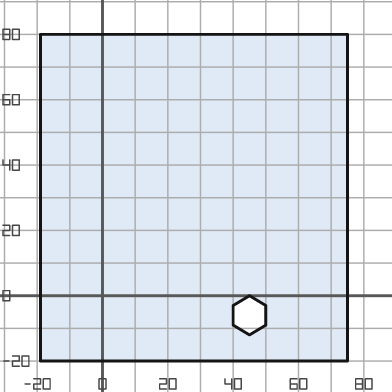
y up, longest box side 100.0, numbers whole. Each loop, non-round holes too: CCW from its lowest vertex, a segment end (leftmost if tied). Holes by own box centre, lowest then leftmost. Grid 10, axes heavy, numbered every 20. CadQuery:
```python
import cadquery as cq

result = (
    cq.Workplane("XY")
    .moveTo(-19.0, -20.0)
    .lineTo(75.0, -20.0)
    .lineTo(75.0, 80.0)
    .lineTo(-19.0, 80.0)
    .close()
    .moveTo(45.0, -12.0)
    .lineTo(50.0, -9.0)
    .lineTo(50.0, -3.0)
    .lineTo(45.0, 0.0)
    .lineTo(40.0, -3.0)
    .lineTo(40.0, -9.0)
    .close()
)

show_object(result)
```